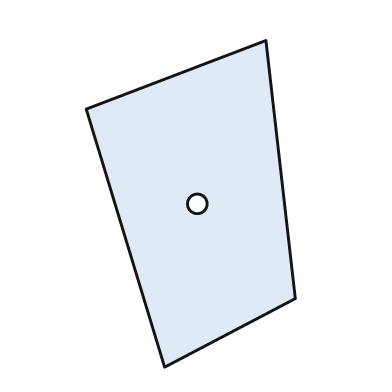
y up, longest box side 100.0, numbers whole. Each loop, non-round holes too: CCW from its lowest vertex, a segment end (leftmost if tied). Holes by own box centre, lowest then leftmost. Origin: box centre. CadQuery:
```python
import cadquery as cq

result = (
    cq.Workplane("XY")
    .moveTo(-8.0, -50.0)
    .lineTo(32.0, -29.0)
    .lineTo(23.0, 50.0)
    .lineTo(-32.0, 29.0)
    .close()
    .moveTo(2.0, 0.0)
    .circle(3.0)
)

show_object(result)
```